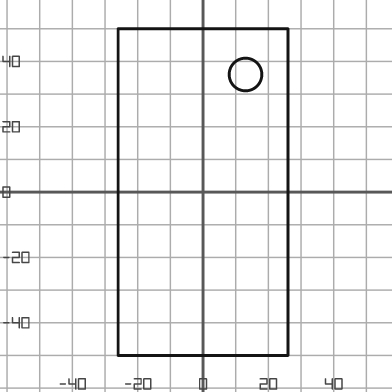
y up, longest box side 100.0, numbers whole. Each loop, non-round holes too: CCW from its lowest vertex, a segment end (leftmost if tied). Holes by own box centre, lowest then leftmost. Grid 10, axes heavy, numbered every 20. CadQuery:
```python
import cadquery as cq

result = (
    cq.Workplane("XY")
    .moveTo(-26.0, -50.0)
    .lineTo(26.0, -50.0)
    .lineTo(26.0, 50.0)
    .lineTo(-26.0, 50.0)
    .close()
    .moveTo(13.0, 36.0)
    .circle(5.0)
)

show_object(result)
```